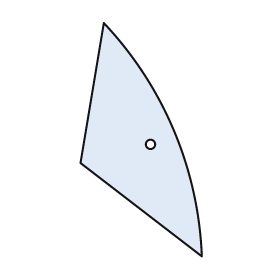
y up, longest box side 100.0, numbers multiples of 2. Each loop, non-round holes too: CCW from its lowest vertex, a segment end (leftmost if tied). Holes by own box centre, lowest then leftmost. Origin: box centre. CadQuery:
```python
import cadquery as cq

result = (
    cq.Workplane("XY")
    .moveTo(26.0, -50.0)
    .threePointArc((14.0, 4.0), (-16.0, 50.0))
    .lineTo(-26.0, -10.0)
    .close()
    .moveTo(4.0, -2.0)
    .circle(2.0)
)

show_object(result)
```